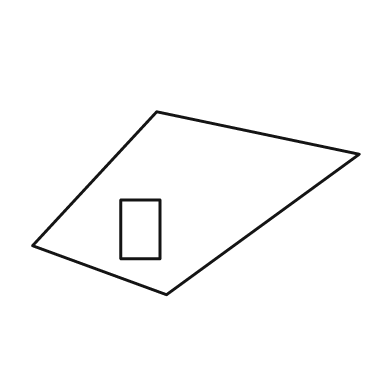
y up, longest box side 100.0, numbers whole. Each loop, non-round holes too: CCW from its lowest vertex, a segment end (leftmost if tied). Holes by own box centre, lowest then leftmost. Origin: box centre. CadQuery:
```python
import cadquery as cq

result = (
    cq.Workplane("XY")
    .moveTo(-9.0, -28.0)
    .lineTo(50.0, 15.0)
    .lineTo(-12.0, 28.0)
    .lineTo(-50.0, -13.0)
    .close()
    .moveTo(-23.0, -17.0)
    .lineTo(-11.0, -17.0)
    .lineTo(-11.0, 1.0)
    .lineTo(-23.0, 1.0)
    .close()
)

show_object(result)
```